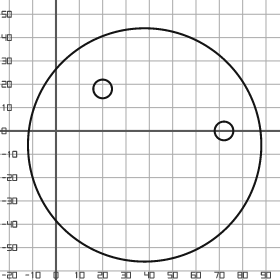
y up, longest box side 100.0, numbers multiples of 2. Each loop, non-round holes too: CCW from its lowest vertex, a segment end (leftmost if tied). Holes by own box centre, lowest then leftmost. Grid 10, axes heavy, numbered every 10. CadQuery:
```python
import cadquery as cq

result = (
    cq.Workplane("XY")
    .moveTo(38.0, -6.0)
    .circle(50.0)
    .moveTo(72.0, 0.0)
    .circle(4.0)
    .moveTo(20.0, 18.0)
    .circle(4.0)
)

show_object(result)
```